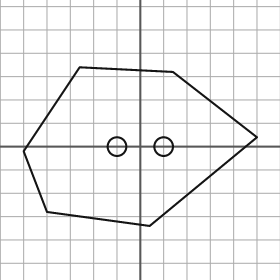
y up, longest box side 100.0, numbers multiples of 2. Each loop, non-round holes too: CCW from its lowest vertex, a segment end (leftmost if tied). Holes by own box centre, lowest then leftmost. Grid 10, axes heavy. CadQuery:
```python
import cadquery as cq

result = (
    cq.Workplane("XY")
    .moveTo(4.0, -34.0)
    .lineTo(50.0, 4.0)
    .lineTo(14.0, 32.0)
    .lineTo(-26.0, 34.0)
    .lineTo(-50.0, -2.0)
    .lineTo(-40.0, -28.0)
    .close()
    .moveTo(-10.0, 0.0)
    .circle(4.0)
    .moveTo(10.0, 0.0)
    .circle(4.0)
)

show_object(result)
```